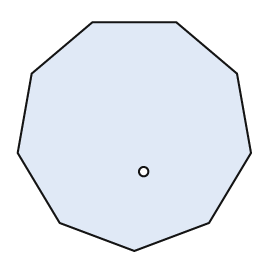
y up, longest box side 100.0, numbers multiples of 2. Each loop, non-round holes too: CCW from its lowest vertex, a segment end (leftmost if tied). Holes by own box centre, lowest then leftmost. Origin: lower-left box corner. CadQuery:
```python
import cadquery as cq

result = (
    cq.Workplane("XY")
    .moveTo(50.0, 0.0)
    .lineTo(82.0, 12.0)
    .lineTo(100.0, 42.0)
    .lineTo(94.0, 76.0)
    .lineTo(68.0, 98.0)
    .lineTo(32.0, 98.0)
    .lineTo(6.0, 76.0)
    .lineTo(0.0, 42.0)
    .lineTo(18.0, 12.0)
    .close()
    .moveTo(54.0, 34.0)
    .circle(2.0)
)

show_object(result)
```